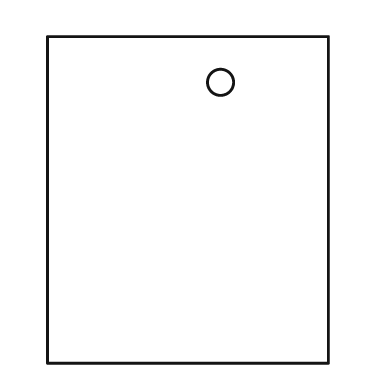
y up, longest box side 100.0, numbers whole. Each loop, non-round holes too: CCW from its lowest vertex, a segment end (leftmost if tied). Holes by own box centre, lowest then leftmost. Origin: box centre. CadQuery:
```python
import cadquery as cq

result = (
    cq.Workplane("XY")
    .moveTo(-43.0, -50.0)
    .lineTo(43.0, -50.0)
    .lineTo(43.0, 50.0)
    .lineTo(-43.0, 50.0)
    .close()
    .moveTo(10.0, 36.0)
    .circle(4.0)
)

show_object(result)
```